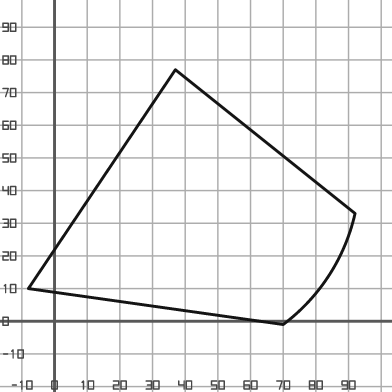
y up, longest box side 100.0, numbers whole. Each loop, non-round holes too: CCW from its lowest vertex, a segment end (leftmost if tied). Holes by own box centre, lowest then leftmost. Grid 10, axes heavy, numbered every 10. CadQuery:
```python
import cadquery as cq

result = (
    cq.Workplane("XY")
    .moveTo(70.0, -1.0)
    .threePointArc((84.0, 14.0), (92.0, 33.0))
    .lineTo(37.0, 77.0)
    .lineTo(-8.0, 10.0)
    .close()
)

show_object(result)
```